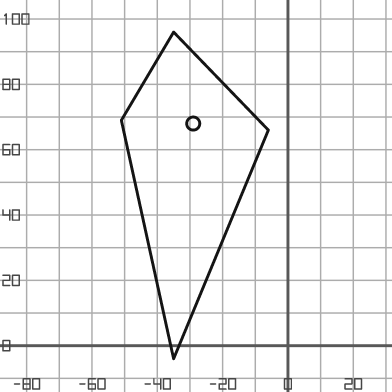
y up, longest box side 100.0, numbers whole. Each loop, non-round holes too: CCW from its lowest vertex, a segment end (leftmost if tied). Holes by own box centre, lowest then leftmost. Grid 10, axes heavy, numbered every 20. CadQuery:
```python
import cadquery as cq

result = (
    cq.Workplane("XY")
    .moveTo(-35.0, -4.0)
    .lineTo(-6.0, 66.0)
    .lineTo(-35.0, 96.0)
    .lineTo(-51.0, 69.0)
    .close()
    .moveTo(-29.0, 68.0)
    .circle(2.0)
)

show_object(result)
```